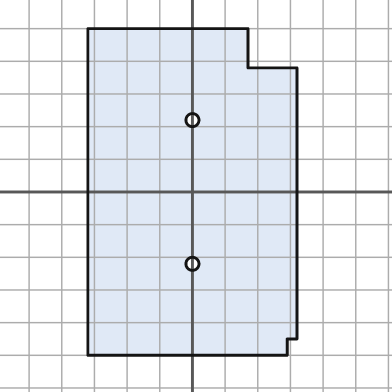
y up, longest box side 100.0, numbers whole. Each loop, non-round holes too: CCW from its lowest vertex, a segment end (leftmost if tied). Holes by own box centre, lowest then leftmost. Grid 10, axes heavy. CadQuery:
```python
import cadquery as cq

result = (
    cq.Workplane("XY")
    .moveTo(-32.0, -50.0)
    .lineTo(29.0, -50.0)
    .lineTo(29.0, -45.0)
    .lineTo(32.0, -45.0)
    .lineTo(32.0, 38.0)
    .lineTo(17.0, 38.0)
    .lineTo(17.0, 50.0)
    .lineTo(-32.0, 50.0)
    .close()
    .moveTo(0.0, -22.0)
    .circle(2.0)
    .moveTo(0.0, 22.0)
    .circle(2.0)
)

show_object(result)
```